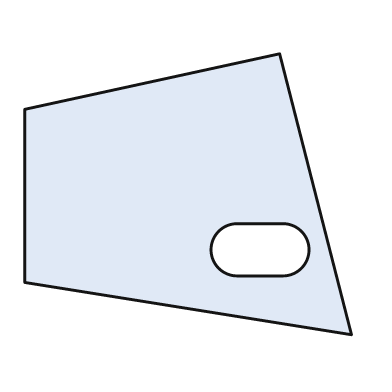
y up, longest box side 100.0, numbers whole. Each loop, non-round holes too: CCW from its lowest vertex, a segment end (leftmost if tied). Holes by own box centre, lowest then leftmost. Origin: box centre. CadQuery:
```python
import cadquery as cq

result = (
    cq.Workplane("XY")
    .moveTo(50.0, -43.0)
    .lineTo(28.0, 43.0)
    .lineTo(-50.0, 26.0)
    .lineTo(-50.0, -27.0)
    .close()
    .moveTo(15.0, -25.0)
    .lineTo(29.0, -25.0)
    .threePointArc((37.0, -17.0), (29.0, -9.0))
    .lineTo(15.0, -9.0)
    .threePointArc((7.0, -17.0), (15.0, -25.0))
    .close()
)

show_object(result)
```